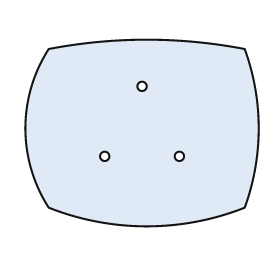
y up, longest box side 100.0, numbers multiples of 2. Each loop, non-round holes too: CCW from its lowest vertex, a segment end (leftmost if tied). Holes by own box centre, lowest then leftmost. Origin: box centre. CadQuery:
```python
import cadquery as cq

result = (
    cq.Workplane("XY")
    .moveTo(-40.0, -32.0)
    .threePointArc((2.0, -40.0), (44.0, -32.0))
    .threePointArc((50.0, 2.0), (44.0, 36.0))
    .threePointArc((2.0, 40.0), (-40.0, 36.0))
    .threePointArc((-50.0, 2.0), (-40.0, -32.0))
    .close()
    .moveTo(-16.0, -10.0)
    .circle(2.0)
    .moveTo(16.0, -10.0)
    .circle(2.0)
    .moveTo(0.0, 20.0)
    .circle(2.0)
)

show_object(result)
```